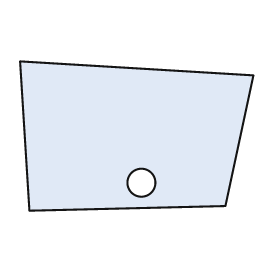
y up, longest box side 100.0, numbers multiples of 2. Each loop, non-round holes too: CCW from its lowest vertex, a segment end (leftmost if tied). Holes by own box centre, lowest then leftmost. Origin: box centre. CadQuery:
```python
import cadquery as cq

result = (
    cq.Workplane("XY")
    .moveTo(-46.0, -32.0)
    .lineTo(38.0, -30.0)
    .lineTo(50.0, 26.0)
    .lineTo(-50.0, 32.0)
    .close()
    .moveTo(2.0, -20.0)
    .circle(6.0)
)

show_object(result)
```